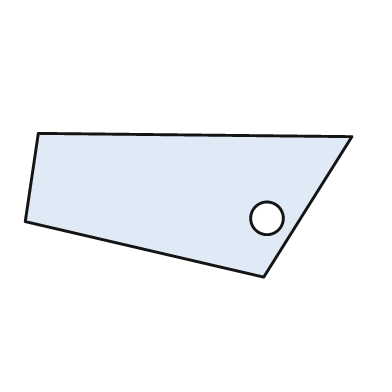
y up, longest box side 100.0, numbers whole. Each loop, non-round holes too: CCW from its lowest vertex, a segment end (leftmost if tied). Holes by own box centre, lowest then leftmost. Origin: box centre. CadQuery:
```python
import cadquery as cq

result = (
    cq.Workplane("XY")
    .moveTo(23.0, -22.0)
    .lineTo(50.0, 21.0)
    .lineTo(-46.0, 22.0)
    .lineTo(-50.0, -5.0)
    .close()
    .moveTo(24.0, -4.0)
    .circle(5.0)
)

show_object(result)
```